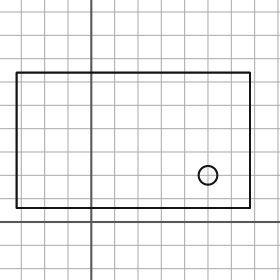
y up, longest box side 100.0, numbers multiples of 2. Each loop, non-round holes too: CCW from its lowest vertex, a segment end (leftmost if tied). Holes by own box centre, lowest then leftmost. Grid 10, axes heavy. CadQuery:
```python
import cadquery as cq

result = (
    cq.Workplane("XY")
    .moveTo(-32.0, 6.0)
    .lineTo(68.0, 6.0)
    .lineTo(68.0, 64.0)
    .lineTo(-32.0, 64.0)
    .close()
    .moveTo(50.0, 20.0)
    .circle(4.0)
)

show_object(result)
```